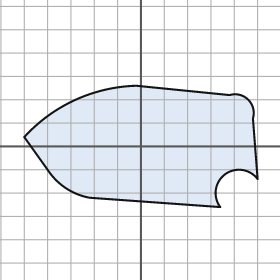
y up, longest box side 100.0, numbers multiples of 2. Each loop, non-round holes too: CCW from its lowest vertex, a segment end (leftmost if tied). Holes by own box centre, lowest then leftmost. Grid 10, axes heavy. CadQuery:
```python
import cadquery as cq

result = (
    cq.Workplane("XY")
    .moveTo(34.0, -26.0)
    .threePointArc((36.0, -12.0), (50.0, -14.0))
    .lineTo(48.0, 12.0)
    .threePointArc((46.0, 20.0), (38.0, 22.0))
    .lineTo(-2.0, 26.0)
    .threePointArc((-28.0, 20.0), (-50.0, 4.0))
    .lineTo(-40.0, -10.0)
    .threePointArc((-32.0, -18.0), (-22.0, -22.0))
    .close()
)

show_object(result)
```